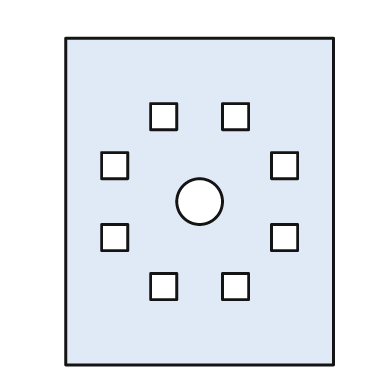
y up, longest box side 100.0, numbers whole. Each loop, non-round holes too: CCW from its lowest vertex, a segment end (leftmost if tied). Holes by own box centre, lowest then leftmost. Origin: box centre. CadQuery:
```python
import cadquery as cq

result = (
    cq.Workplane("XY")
    .moveTo(-41.0, -50.0)
    .lineTo(41.0, -50.0)
    .lineTo(41.0, 50.0)
    .lineTo(-41.0, 50.0)
    .close()
    .moveTo(-15.0, -30.0)
    .lineTo(-7.0, -30.0)
    .lineTo(-7.0, -22.0)
    .lineTo(-15.0, -22.0)
    .close()
    .moveTo(7.0, -30.0)
    .lineTo(15.0, -30.0)
    .lineTo(15.0, -22.0)
    .lineTo(7.0, -22.0)
    .close()
    .moveTo(-30.0, -15.0)
    .lineTo(-22.0, -15.0)
    .lineTo(-22.0, -7.0)
    .lineTo(-30.0, -7.0)
    .close()
    .moveTo(22.0, -15.0)
    .lineTo(30.0, -15.0)
    .lineTo(30.0, -7.0)
    .lineTo(22.0, -7.0)
    .close()
    .moveTo(0.0, 0.0)
    .circle(7.0)
    .moveTo(-30.0, 7.0)
    .lineTo(-22.0, 7.0)
    .lineTo(-22.0, 15.0)
    .lineTo(-30.0, 15.0)
    .close()
    .moveTo(22.0, 7.0)
    .lineTo(30.0, 7.0)
    .lineTo(30.0, 15.0)
    .lineTo(22.0, 15.0)
    .close()
    .moveTo(-15.0, 22.0)
    .lineTo(-7.0, 22.0)
    .lineTo(-7.0, 30.0)
    .lineTo(-15.0, 30.0)
    .close()
    .moveTo(7.0, 22.0)
    .lineTo(15.0, 22.0)
    .lineTo(15.0, 30.0)
    .lineTo(7.0, 30.0)
    .close()
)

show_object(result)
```